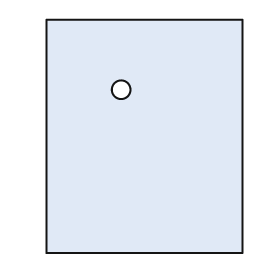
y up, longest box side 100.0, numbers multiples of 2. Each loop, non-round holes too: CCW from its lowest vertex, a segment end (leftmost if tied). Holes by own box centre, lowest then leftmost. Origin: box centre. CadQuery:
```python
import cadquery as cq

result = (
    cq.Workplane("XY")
    .moveTo(-42.0, -50.0)
    .lineTo(42.0, -50.0)
    .lineTo(42.0, 50.0)
    .lineTo(-42.0, 50.0)
    .close()
    .moveTo(-10.0, 20.0)
    .circle(4.0)
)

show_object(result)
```